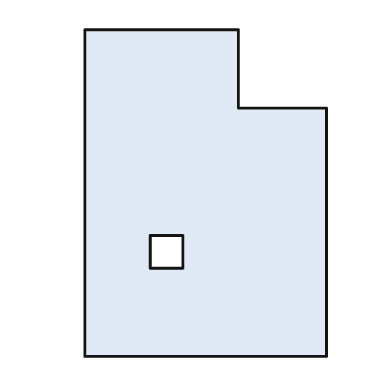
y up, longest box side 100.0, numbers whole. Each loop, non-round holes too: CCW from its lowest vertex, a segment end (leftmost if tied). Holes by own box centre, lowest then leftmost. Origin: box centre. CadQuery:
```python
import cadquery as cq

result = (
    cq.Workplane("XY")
    .moveTo(-37.0, -50.0)
    .lineTo(37.0, -50.0)
    .lineTo(37.0, 26.0)
    .lineTo(10.0, 26.0)
    .lineTo(10.0, 50.0)
    .lineTo(-37.0, 50.0)
    .close()
    .moveTo(-17.0, -23.0)
    .lineTo(-7.0, -23.0)
    .lineTo(-7.0, -13.0)
    .lineTo(-17.0, -13.0)
    .close()
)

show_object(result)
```